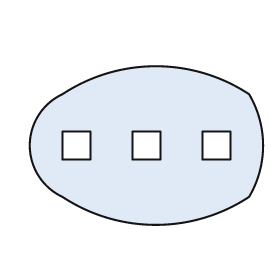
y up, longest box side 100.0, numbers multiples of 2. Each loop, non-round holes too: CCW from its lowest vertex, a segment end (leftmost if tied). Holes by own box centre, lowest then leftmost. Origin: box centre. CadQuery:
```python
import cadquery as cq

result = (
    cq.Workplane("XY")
    .moveTo(-36.0, -22.0)
    .threePointArc((4.0, -34.0), (44.0, -22.0))
    .threePointArc((50.0, 0.0), (44.0, 22.0))
    .threePointArc((4.0, 34.0), (-36.0, 22.0))
    .threePointArc((-50.0, 0.0), (-36.0, -22.0))
    .close()
    .moveTo(-36.0, -6.0)
    .lineTo(-24.0, -6.0)
    .lineTo(-24.0, 6.0)
    .lineTo(-36.0, 6.0)
    .close()
    .moveTo(-6.0, -6.0)
    .lineTo(6.0, -6.0)
    .lineTo(6.0, 6.0)
    .lineTo(-6.0, 6.0)
    .close()
    .moveTo(24.0, -6.0)
    .lineTo(36.0, -6.0)
    .lineTo(36.0, 6.0)
    .lineTo(24.0, 6.0)
    .close()
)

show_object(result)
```